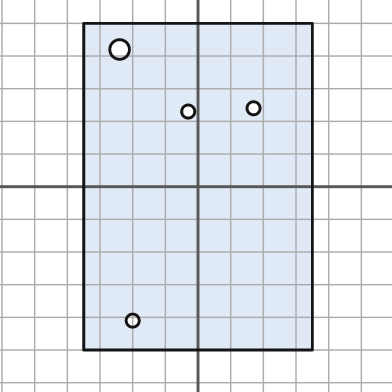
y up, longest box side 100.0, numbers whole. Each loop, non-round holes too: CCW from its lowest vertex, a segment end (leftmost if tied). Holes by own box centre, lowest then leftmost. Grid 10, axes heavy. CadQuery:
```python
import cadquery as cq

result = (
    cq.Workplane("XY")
    .moveTo(-35.0, -50.0)
    .lineTo(35.0, -50.0)
    .lineTo(35.0, 50.0)
    .lineTo(-35.0, 50.0)
    .close()
    .moveTo(-20.0, -41.0)
    .circle(2.0)
    .moveTo(-3.0, 23.0)
    .circle(2.0)
    .moveTo(17.0, 24.0)
    .circle(2.0)
    .moveTo(-24.0, 42.0)
    .circle(3.0)
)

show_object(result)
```